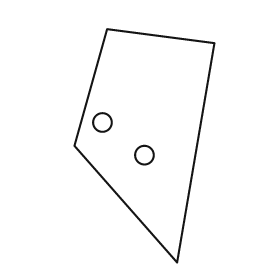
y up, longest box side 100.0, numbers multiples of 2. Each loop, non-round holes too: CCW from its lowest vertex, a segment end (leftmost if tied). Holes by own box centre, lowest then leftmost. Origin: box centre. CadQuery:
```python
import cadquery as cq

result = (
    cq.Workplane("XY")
    .moveTo(14.0, -50.0)
    .lineTo(30.0, 44.0)
    .lineTo(-16.0, 50.0)
    .lineTo(-30.0, 0.0)
    .close()
    .moveTo(0.0, -4.0)
    .circle(4.0)
    .moveTo(-18.0, 10.0)
    .circle(4.0)
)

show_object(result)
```